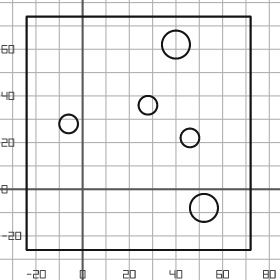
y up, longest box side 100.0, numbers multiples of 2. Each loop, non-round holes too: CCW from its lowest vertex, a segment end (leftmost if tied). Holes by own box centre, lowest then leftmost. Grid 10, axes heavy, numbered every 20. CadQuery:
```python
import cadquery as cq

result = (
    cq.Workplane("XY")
    .moveTo(-24.0, -26.0)
    .lineTo(72.0, -26.0)
    .lineTo(72.0, 74.0)
    .lineTo(-24.0, 74.0)
    .close()
    .moveTo(52.0, -8.0)
    .circle(6.0)
    .moveTo(46.0, 22.0)
    .circle(4.0)
    .moveTo(-6.0, 28.0)
    .circle(4.0)
    .moveTo(28.0, 36.0)
    .circle(4.0)
    .moveTo(40.0, 62.0)
    .circle(6.0)
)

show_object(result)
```